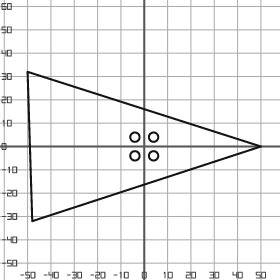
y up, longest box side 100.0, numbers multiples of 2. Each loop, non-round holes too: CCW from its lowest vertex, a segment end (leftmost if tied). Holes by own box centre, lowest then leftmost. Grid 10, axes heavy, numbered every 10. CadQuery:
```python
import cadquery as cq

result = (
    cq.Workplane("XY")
    .moveTo(-48.0, -32.0)
    .lineTo(50.0, 0.0)
    .lineTo(-50.0, 32.0)
    .close()
    .moveTo(-4.0, -4.0)
    .circle(2.0)
    .moveTo(4.0, -4.0)
    .circle(2.0)
    .moveTo(-4.0, 4.0)
    .circle(2.0)
    .moveTo(4.0, 4.0)
    .circle(2.0)
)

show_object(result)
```